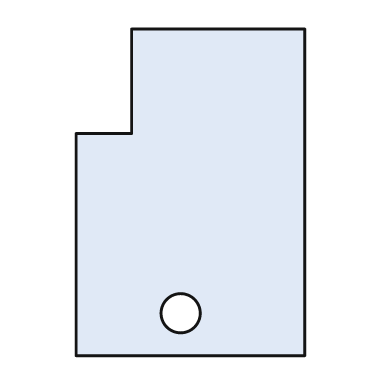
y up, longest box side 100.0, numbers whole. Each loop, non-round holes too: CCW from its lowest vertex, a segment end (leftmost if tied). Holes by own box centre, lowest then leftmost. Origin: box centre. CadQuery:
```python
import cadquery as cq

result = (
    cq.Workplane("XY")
    .moveTo(-35.0, -50.0)
    .lineTo(35.0, -50.0)
    .lineTo(35.0, 50.0)
    .lineTo(-18.0, 50.0)
    .lineTo(-18.0, 18.0)
    .lineTo(-35.0, 18.0)
    .close()
    .moveTo(-3.0, -37.0)
    .circle(6.0)
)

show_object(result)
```